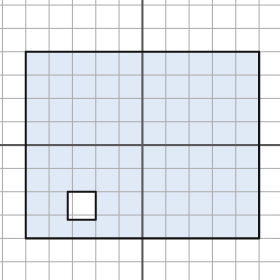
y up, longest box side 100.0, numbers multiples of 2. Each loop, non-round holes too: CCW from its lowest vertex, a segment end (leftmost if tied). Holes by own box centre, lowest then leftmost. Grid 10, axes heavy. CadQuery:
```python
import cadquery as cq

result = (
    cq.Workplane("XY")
    .moveTo(-50.0, -40.0)
    .lineTo(50.0, -40.0)
    .lineTo(50.0, 40.0)
    .lineTo(-50.0, 40.0)
    .close()
    .moveTo(-32.0, -32.0)
    .lineTo(-20.0, -32.0)
    .lineTo(-20.0, -20.0)
    .lineTo(-32.0, -20.0)
    .close()
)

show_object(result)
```